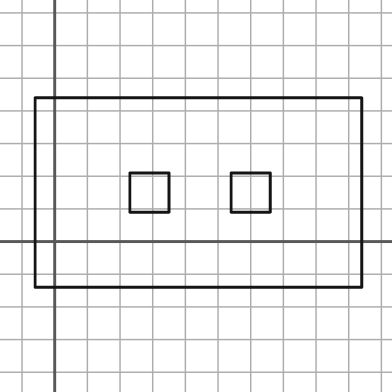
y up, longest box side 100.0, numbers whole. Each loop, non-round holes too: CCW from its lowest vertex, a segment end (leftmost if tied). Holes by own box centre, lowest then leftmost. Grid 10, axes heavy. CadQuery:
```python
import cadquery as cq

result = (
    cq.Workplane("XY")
    .moveTo(-6.0, -14.0)
    .lineTo(94.0, -14.0)
    .lineTo(94.0, 44.0)
    .lineTo(-6.0, 44.0)
    .close()
    .moveTo(23.0, 9.0)
    .lineTo(35.0, 9.0)
    .lineTo(35.0, 21.0)
    .lineTo(23.0, 21.0)
    .close()
    .moveTo(54.0, 9.0)
    .lineTo(66.0, 9.0)
    .lineTo(66.0, 21.0)
    .lineTo(54.0, 21.0)
    .close()
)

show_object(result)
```